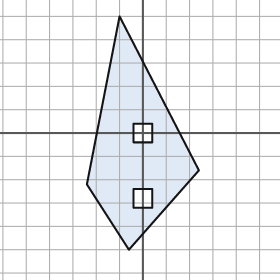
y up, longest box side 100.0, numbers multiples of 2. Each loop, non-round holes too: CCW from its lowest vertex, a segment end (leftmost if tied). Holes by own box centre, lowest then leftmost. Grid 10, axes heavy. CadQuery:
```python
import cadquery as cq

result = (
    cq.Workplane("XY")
    .moveTo(-6.0, -50.0)
    .lineTo(24.0, -16.0)
    .lineTo(-10.0, 50.0)
    .lineTo(-24.0, -22.0)
    .close()
    .moveTo(-4.0, -32.0)
    .lineTo(4.0, -32.0)
    .lineTo(4.0, -24.0)
    .lineTo(-4.0, -24.0)
    .close()
    .moveTo(-4.0, -4.0)
    .lineTo(4.0, -4.0)
    .lineTo(4.0, 4.0)
    .lineTo(-4.0, 4.0)
    .close()
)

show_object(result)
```